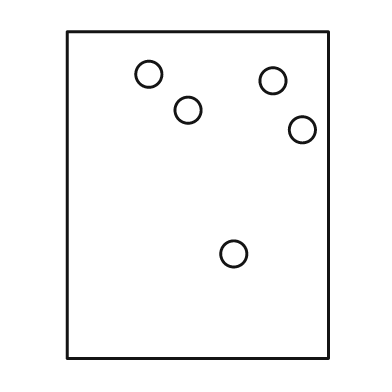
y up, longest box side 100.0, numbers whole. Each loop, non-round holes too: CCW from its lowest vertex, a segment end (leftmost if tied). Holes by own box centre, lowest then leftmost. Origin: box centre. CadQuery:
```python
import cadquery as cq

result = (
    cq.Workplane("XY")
    .moveTo(-40.0, -50.0)
    .lineTo(40.0, -50.0)
    .lineTo(40.0, 50.0)
    .lineTo(-40.0, 50.0)
    .close()
    .moveTo(11.0, -18.0)
    .circle(4.0)
    .moveTo(32.0, 20.0)
    .circle(4.0)
    .moveTo(-3.0, 26.0)
    .circle(4.0)
    .moveTo(23.0, 35.0)
    .circle(4.0)
    .moveTo(-15.0, 37.0)
    .circle(4.0)
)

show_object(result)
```